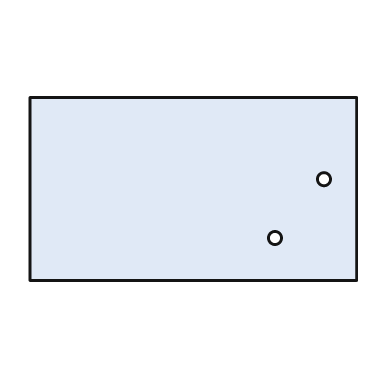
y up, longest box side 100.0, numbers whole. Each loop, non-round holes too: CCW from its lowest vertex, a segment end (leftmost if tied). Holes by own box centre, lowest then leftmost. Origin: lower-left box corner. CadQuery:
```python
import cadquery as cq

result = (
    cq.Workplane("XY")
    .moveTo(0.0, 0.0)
    .lineTo(100.0, 0.0)
    .lineTo(100.0, 56.0)
    .lineTo(0.0, 56.0)
    .close()
    .moveTo(75.0, 13.0)
    .circle(2.0)
    .moveTo(90.0, 31.0)
    .circle(2.0)
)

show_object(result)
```